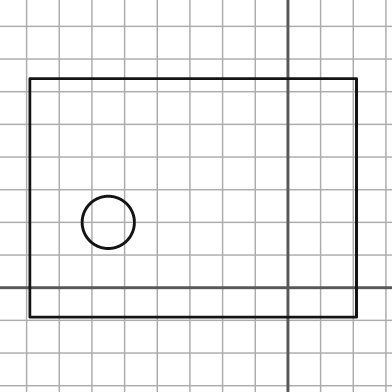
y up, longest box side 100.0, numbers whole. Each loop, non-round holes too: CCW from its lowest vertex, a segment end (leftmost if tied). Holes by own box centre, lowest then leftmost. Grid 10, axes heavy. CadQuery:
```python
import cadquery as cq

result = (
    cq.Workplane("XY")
    .moveTo(-79.0, -9.0)
    .lineTo(21.0, -9.0)
    .lineTo(21.0, 64.0)
    .lineTo(-79.0, 64.0)
    .close()
    .moveTo(-55.0, 20.0)
    .circle(8.0)
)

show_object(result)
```